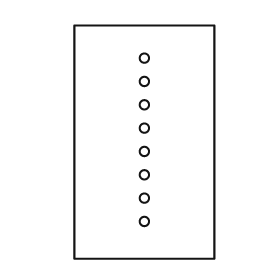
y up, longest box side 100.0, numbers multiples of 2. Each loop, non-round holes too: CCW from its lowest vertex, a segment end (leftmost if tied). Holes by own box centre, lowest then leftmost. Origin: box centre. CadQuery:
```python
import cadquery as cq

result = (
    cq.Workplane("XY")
    .moveTo(-30.0, -50.0)
    .lineTo(30.0, -50.0)
    .lineTo(30.0, 50.0)
    .lineTo(-30.0, 50.0)
    .close()
    .moveTo(0.0, -34.0)
    .circle(2.0)
    .moveTo(0.0, -24.0)
    .circle(2.0)
    .moveTo(0.0, -14.0)
    .circle(2.0)
    .moveTo(0.0, -4.0)
    .circle(2.0)
    .moveTo(0.0, 6.0)
    .circle(2.0)
    .moveTo(0.0, 16.0)
    .circle(2.0)
    .moveTo(0.0, 26.0)
    .circle(2.0)
    .moveTo(0.0, 36.0)
    .circle(2.0)
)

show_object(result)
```